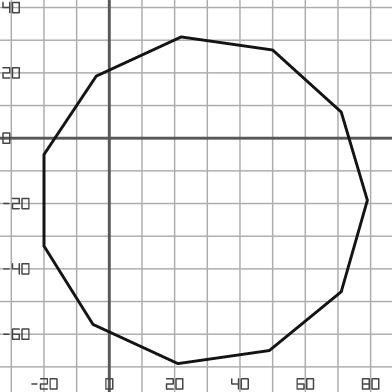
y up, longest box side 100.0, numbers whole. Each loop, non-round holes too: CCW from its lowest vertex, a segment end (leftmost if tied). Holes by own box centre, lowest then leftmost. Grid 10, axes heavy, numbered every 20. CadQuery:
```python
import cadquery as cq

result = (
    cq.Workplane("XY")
    .moveTo(21.0, -69.0)
    .lineTo(49.0, -65.0)
    .lineTo(71.0, -47.0)
    .lineTo(79.0, -19.0)
    .lineTo(71.0, 8.0)
    .lineTo(50.0, 27.0)
    .lineTo(22.0, 31.0)
    .lineTo(-4.0, 19.0)
    .lineTo(-20.0, -5.0)
    .lineTo(-20.0, -33.0)
    .lineTo(-5.0, -57.0)
    .close()
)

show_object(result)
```